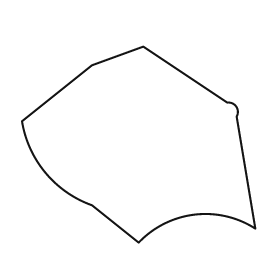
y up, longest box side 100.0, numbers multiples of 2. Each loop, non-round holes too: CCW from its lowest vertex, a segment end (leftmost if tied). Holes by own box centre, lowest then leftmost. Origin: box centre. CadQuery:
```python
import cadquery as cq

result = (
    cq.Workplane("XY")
    .moveTo(0.0, -42.0)
    .threePointArc((24.0, -30.0), (50.0, -36.0))
    .lineTo(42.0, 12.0)
    .threePointArc((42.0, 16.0), (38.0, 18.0))
    .lineTo(2.0, 42.0)
    .lineTo(-20.0, 34.0)
    .lineTo(-50.0, 10.0)
    .threePointArc((-40.0, -12.0), (-20.0, -26.0))
    .close()
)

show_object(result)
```